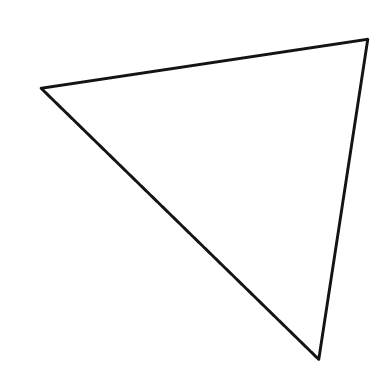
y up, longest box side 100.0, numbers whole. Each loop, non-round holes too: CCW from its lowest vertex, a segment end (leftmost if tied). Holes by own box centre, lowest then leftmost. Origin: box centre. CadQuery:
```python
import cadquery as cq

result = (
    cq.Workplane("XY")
    .moveTo(35.0, -49.0)
    .lineTo(50.0, 49.0)
    .lineTo(-50.0, 34.0)
    .close()
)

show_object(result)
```